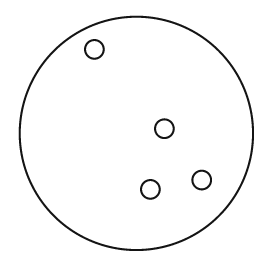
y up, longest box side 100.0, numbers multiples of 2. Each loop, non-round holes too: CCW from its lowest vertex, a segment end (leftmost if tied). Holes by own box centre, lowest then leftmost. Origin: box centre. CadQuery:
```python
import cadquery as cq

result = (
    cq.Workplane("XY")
    .moveTo(0.0, 0.0)
    .circle(50.0)
    .moveTo(6.0, -24.0)
    .circle(4.0)
    .moveTo(28.0, -20.0)
    .circle(4.0)
    .moveTo(12.0, 2.0)
    .circle(4.0)
    .moveTo(-18.0, 36.0)
    .circle(4.0)
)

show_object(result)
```